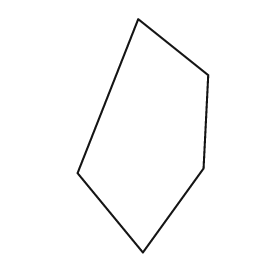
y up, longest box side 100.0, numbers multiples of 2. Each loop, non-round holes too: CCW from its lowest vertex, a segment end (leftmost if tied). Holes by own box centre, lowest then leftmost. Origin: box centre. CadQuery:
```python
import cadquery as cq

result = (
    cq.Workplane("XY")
    .moveTo(0.0, -50.0)
    .lineTo(26.0, -14.0)
    .lineTo(28.0, 26.0)
    .lineTo(-2.0, 50.0)
    .lineTo(-28.0, -16.0)
    .close()
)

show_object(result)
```